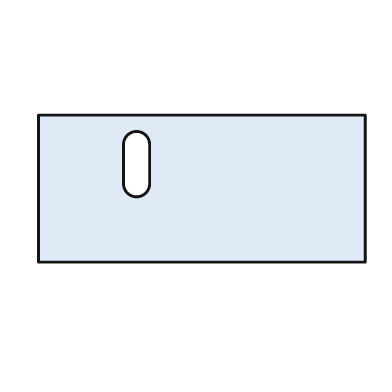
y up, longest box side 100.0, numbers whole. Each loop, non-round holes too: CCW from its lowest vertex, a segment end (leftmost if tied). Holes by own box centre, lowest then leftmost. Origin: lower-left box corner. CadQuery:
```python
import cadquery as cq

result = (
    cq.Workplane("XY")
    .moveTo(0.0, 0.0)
    .lineTo(100.0, 0.0)
    .lineTo(100.0, 45.0)
    .lineTo(0.0, 45.0)
    .close()
    .moveTo(26.0, 24.0)
    .threePointArc((30.0, 20.0), (34.0, 24.0))
    .lineTo(34.0, 36.0)
    .threePointArc((30.0, 40.0), (26.0, 36.0))
    .close()
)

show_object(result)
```